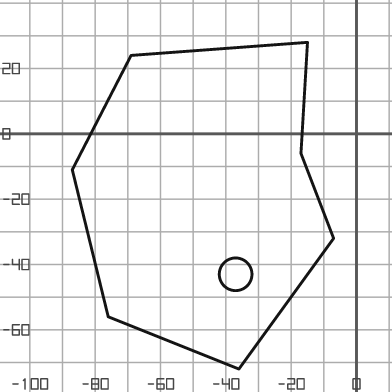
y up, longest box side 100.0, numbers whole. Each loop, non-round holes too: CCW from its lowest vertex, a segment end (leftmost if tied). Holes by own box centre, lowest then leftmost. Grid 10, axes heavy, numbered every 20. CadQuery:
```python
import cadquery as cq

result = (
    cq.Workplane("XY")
    .moveTo(-36.0, -72.0)
    .lineTo(-7.0, -32.0)
    .lineTo(-17.0, -6.0)
    .lineTo(-15.0, 28.0)
    .lineTo(-69.0, 24.0)
    .lineTo(-87.0, -11.0)
    .lineTo(-76.0, -56.0)
    .close()
    .moveTo(-37.0, -43.0)
    .circle(5.0)
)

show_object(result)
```